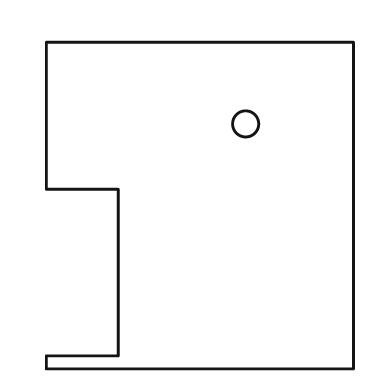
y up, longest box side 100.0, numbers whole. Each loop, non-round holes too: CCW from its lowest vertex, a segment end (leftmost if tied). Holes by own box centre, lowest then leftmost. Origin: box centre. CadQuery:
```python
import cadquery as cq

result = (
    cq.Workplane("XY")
    .moveTo(-47.0, -50.0)
    .lineTo(47.0, -50.0)
    .lineTo(47.0, 50.0)
    .lineTo(-47.0, 50.0)
    .lineTo(-47.0, 5.0)
    .lineTo(-25.0, 5.0)
    .lineTo(-25.0, -46.0)
    .lineTo(-47.0, -46.0)
    .close()
    .moveTo(14.0, 25.0)
    .circle(4.0)
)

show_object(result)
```